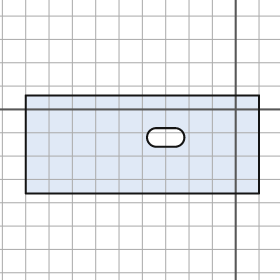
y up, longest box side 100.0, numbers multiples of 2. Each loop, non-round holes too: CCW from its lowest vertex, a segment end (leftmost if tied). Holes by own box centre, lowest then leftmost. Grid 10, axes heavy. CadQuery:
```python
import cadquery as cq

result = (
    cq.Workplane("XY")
    .moveTo(-90.0, -36.0)
    .lineTo(10.0, -36.0)
    .lineTo(10.0, 6.0)
    .lineTo(-90.0, 6.0)
    .close()
    .moveTo(-34.0, -16.0)
    .lineTo(-26.0, -16.0)
    .threePointArc((-22.0, -12.0), (-26.0, -8.0))
    .lineTo(-34.0, -8.0)
    .threePointArc((-38.0, -12.0), (-34.0, -16.0))
    .close()
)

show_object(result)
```